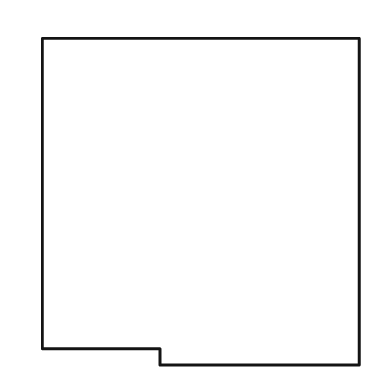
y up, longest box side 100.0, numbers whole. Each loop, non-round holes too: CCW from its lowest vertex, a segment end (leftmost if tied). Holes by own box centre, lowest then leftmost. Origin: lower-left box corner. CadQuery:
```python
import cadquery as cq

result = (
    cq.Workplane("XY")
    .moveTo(36.0, 0.0)
    .lineTo(97.0, 0.0)
    .lineTo(97.0, 100.0)
    .lineTo(0.0, 100.0)
    .lineTo(0.0, 5.0)
    .lineTo(36.0, 5.0)
    .close()
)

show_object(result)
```